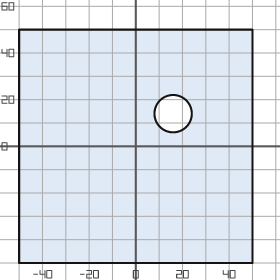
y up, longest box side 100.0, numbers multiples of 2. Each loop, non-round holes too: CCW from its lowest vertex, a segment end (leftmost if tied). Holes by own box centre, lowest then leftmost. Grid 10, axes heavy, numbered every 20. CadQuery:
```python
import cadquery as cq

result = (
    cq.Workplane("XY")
    .moveTo(-50.0, -50.0)
    .lineTo(50.0, -50.0)
    .lineTo(50.0, 50.0)
    .lineTo(-50.0, 50.0)
    .close()
    .moveTo(16.0, 14.0)
    .circle(8.0)
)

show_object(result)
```